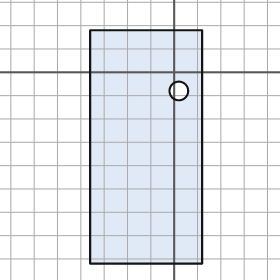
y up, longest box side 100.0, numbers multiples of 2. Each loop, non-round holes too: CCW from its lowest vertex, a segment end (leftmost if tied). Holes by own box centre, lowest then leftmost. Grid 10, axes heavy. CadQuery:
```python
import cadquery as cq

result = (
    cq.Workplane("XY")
    .moveTo(-36.0, -82.0)
    .lineTo(12.0, -82.0)
    .lineTo(12.0, 18.0)
    .lineTo(-36.0, 18.0)
    .close()
    .moveTo(2.0, -8.0)
    .circle(4.0)
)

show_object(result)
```